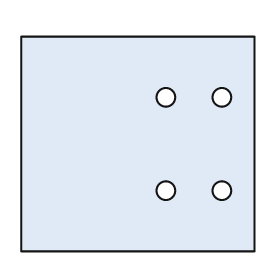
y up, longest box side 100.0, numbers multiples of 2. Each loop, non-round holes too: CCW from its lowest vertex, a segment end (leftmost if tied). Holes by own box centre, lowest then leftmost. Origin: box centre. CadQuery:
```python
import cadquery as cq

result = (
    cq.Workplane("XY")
    .moveTo(-50.0, -46.0)
    .lineTo(50.0, -46.0)
    .lineTo(50.0, 46.0)
    .lineTo(-50.0, 46.0)
    .close()
    .moveTo(12.0, -20.0)
    .circle(4.0)
    .moveTo(36.0, -20.0)
    .circle(4.0)
    .moveTo(12.0, 20.0)
    .circle(4.0)
    .moveTo(36.0, 20.0)
    .circle(4.0)
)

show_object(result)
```